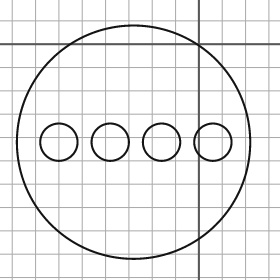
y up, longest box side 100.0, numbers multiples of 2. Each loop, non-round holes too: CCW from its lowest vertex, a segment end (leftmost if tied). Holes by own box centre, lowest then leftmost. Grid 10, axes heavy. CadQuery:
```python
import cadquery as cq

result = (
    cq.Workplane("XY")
    .moveTo(-28.0, -42.0)
    .circle(50.0)
    .moveTo(-60.0, -42.0)
    .circle(8.0)
    .moveTo(-38.0, -42.0)
    .circle(8.0)
    .moveTo(-16.0, -42.0)
    .circle(8.0)
    .moveTo(6.0, -42.0)
    .circle(8.0)
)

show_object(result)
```